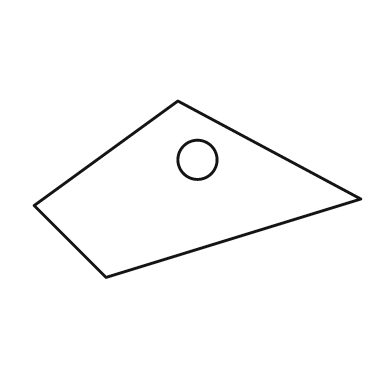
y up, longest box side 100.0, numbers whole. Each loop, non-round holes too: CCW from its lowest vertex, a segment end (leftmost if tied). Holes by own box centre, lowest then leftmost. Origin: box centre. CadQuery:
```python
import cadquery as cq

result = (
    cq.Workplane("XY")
    .moveTo(-28.0, -27.0)
    .lineTo(50.0, -3.0)
    .lineTo(-6.0, 27.0)
    .lineTo(-50.0, -5.0)
    .close()
    .moveTo(0.0, 9.0)
    .circle(6.0)
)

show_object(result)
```